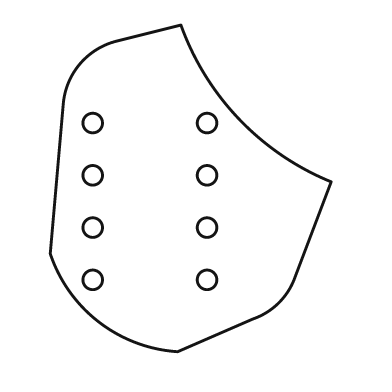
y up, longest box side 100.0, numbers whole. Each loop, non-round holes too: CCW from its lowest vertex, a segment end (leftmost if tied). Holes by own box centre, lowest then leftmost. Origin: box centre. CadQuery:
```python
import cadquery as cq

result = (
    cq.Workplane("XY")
    .moveTo(-4.0, -50.0)
    .lineTo(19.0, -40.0)
    .threePointArc((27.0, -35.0), (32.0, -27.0))
    .lineTo(43.0, 2.0)
    .threePointArc((15.0, 21.0), (-3.0, 50.0))
    .lineTo(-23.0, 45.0)
    .threePointArc((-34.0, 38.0), (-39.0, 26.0))
    .lineTo(-43.0, -20.0)
    .threePointArc((-28.0, -41.0), (-4.0, -50.0))
    .close()
    .moveTo(-30.0, -28.0)
    .circle(3.0)
    .moveTo(5.0, -28.0)
    .circle(3.0)
    .moveTo(-30.0, -12.0)
    .circle(3.0)
    .moveTo(5.0, -12.0)
    .circle(3.0)
    .moveTo(-30.0, 4.0)
    .circle(3.0)
    .moveTo(5.0, 4.0)
    .circle(3.0)
    .moveTo(-30.0, 20.0)
    .circle(3.0)
    .moveTo(5.0, 20.0)
    .circle(3.0)
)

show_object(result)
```